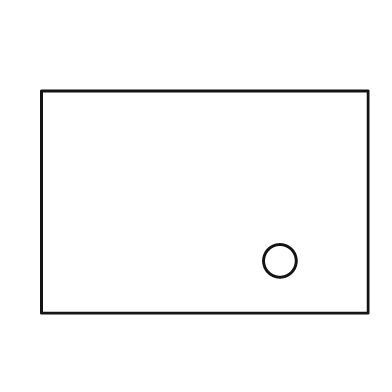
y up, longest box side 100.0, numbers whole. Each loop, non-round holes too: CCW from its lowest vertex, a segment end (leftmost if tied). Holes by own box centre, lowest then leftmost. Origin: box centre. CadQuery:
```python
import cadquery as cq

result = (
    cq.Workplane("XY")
    .moveTo(-50.0, -34.0)
    .lineTo(50.0, -34.0)
    .lineTo(50.0, 34.0)
    .lineTo(-50.0, 34.0)
    .close()
    .moveTo(23.0, -18.0)
    .circle(5.0)
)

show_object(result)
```